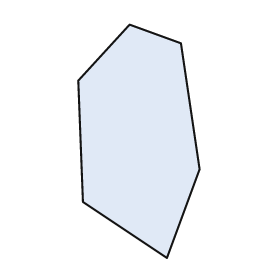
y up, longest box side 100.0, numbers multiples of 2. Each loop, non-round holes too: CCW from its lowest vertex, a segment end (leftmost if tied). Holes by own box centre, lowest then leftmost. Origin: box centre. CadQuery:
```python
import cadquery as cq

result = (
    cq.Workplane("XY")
    .moveTo(12.0, -50.0)
    .lineTo(26.0, -12.0)
    .lineTo(18.0, 42.0)
    .lineTo(-4.0, 50.0)
    .lineTo(-26.0, 26.0)
    .lineTo(-24.0, -26.0)
    .close()
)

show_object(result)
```